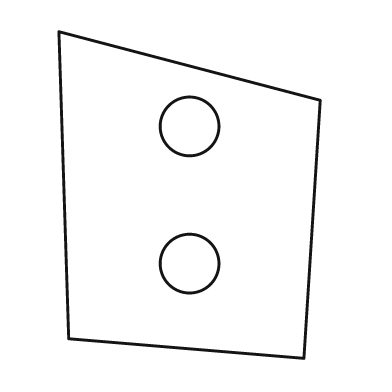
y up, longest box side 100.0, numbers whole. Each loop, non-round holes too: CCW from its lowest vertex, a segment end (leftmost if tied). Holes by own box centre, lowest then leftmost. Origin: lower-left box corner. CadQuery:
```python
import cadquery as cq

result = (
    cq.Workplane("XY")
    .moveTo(75.0, 0.0)
    .lineTo(80.0, 79.0)
    .lineTo(0.0, 100.0)
    .lineTo(3.0, 6.0)
    .close()
    .moveTo(40.0, 29.0)
    .circle(9.0)
    .moveTo(40.0, 71.0)
    .circle(9.0)
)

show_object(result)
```